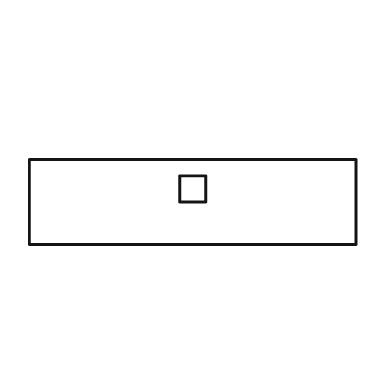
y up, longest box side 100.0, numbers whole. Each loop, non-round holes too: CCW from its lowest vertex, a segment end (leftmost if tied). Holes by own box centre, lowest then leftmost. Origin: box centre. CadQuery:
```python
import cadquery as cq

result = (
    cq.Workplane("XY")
    .moveTo(-50.0, -13.0)
    .lineTo(50.0, -13.0)
    .lineTo(50.0, 13.0)
    .lineTo(-50.0, 13.0)
    .close()
    .moveTo(-4.0, 0.0)
    .lineTo(4.0, 0.0)
    .lineTo(4.0, 8.0)
    .lineTo(-4.0, 8.0)
    .close()
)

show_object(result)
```